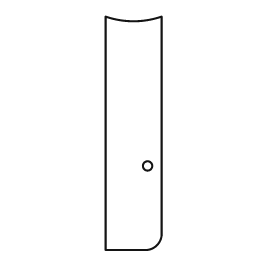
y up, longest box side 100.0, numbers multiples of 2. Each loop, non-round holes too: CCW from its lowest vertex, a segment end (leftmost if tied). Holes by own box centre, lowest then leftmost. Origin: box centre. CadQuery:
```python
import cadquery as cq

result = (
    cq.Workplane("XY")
    .moveTo(-12.0, -50.0)
    .lineTo(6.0, -50.0)
    .threePointArc((10.0, -48.0), (12.0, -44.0))
    .lineTo(12.0, 50.0)
    .threePointArc((0.0, 48.0), (-12.0, 50.0))
    .close()
    .moveTo(6.0, -14.0)
    .circle(2.0)
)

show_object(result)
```